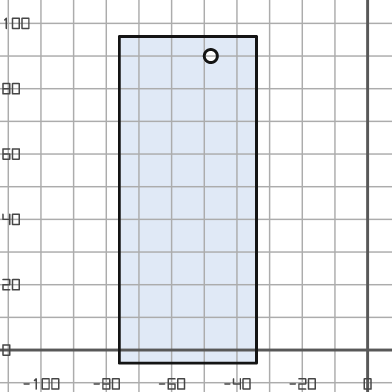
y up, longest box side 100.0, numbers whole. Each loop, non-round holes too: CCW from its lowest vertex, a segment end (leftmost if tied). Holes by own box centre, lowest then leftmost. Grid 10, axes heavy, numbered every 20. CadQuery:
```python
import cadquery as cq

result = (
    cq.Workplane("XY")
    .moveTo(-76.0, -4.0)
    .lineTo(-34.0, -4.0)
    .lineTo(-34.0, 96.0)
    .lineTo(-76.0, 96.0)
    .close()
    .moveTo(-48.0, 90.0)
    .circle(2.0)
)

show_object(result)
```